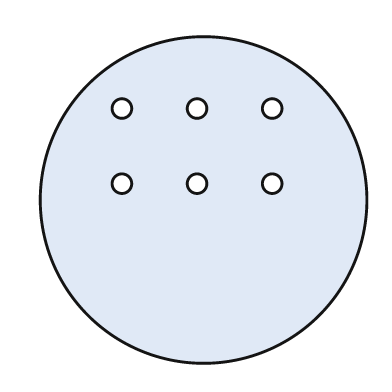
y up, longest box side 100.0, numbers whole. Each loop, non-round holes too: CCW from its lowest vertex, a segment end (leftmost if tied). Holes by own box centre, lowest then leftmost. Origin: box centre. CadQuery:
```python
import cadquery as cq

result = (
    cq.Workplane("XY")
    .moveTo(0.0, 0.0)
    .circle(50.0)
    .moveTo(-25.0, 5.0)
    .circle(3.0)
    .moveTo(-2.0, 5.0)
    .circle(3.0)
    .moveTo(21.0, 5.0)
    .circle(3.0)
    .moveTo(-25.0, 28.0)
    .circle(3.0)
    .moveTo(-2.0, 28.0)
    .circle(3.0)
    .moveTo(21.0, 28.0)
    .circle(3.0)
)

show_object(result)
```